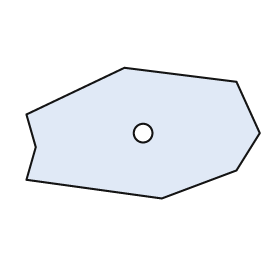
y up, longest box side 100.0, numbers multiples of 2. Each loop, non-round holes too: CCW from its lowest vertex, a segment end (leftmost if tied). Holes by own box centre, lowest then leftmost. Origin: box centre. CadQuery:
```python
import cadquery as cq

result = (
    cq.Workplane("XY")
    .moveTo(8.0, -28.0)
    .lineTo(40.0, -16.0)
    .lineTo(50.0, 0.0)
    .lineTo(40.0, 22.0)
    .lineTo(-8.0, 28.0)
    .lineTo(-50.0, 8.0)
    .lineTo(-46.0, -6.0)
    .lineTo(-50.0, -20.0)
    .close()
    .moveTo(0.0, 0.0)
    .circle(4.0)
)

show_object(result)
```